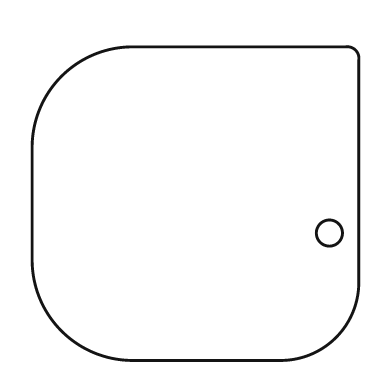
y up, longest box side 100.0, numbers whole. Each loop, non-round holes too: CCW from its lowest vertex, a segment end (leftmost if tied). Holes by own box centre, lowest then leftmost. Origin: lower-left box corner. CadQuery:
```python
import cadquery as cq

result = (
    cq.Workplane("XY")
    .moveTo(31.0, 0.0)
    .lineTo(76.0, 0.0)
    .threePointArc((93.0, 7.0), (100.0, 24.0))
    .lineTo(100.0, 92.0)
    .threePointArc((99.0, 95.0), (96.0, 96.0))
    .lineTo(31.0, 96.0)
    .threePointArc((9.0, 87.0), (0.0, 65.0))
    .lineTo(0.0, 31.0)
    .threePointArc((9.0, 9.0), (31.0, 0.0))
    .close()
    .moveTo(91.0, 39.0)
    .circle(4.0)
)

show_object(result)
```